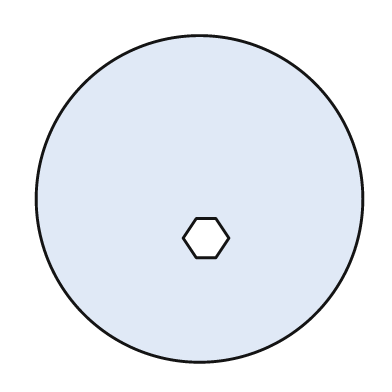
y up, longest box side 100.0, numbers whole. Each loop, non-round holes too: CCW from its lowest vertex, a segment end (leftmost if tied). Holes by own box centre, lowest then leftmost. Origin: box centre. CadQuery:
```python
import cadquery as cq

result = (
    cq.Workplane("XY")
    .moveTo(0.0, 0.0)
    .circle(50.0)
    .moveTo(-1.0, -18.0)
    .lineTo(5.0, -18.0)
    .lineTo(9.0, -12.0)
    .lineTo(5.0, -6.0)
    .lineTo(-1.0, -6.0)
    .lineTo(-5.0, -12.0)
    .close()
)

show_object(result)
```